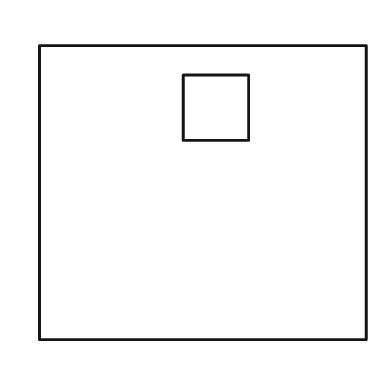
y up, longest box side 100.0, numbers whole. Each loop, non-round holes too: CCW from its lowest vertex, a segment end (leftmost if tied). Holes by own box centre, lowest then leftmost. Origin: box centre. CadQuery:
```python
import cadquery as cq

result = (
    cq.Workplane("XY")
    .moveTo(-50.0, -45.0)
    .lineTo(50.0, -45.0)
    .lineTo(50.0, 45.0)
    .lineTo(-50.0, 45.0)
    .close()
    .moveTo(-6.0, 16.0)
    .lineTo(14.0, 16.0)
    .lineTo(14.0, 36.0)
    .lineTo(-6.0, 36.0)
    .close()
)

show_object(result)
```